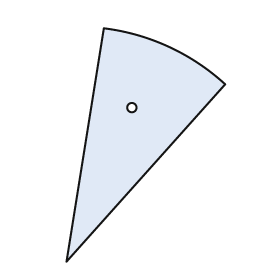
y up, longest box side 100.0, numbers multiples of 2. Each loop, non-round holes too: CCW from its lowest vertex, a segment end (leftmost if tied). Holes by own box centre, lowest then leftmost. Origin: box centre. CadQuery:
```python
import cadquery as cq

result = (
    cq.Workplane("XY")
    .moveTo(-34.0, -50.0)
    .lineTo(34.0, 26.0)
    .threePointArc((10.0, 42.0), (-18.0, 50.0))
    .close()
    .moveTo(-6.0, 16.0)
    .circle(2.0)
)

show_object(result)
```